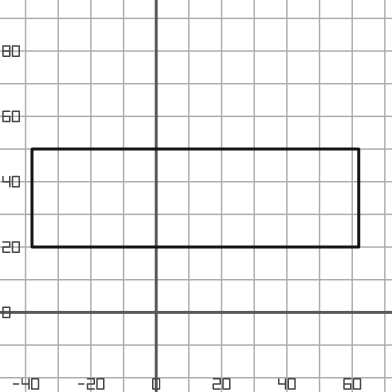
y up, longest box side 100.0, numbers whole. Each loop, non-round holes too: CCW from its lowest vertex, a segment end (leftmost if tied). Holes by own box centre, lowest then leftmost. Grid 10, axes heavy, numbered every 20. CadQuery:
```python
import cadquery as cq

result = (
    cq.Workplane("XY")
    .moveTo(-38.0, 20.0)
    .lineTo(62.0, 20.0)
    .lineTo(62.0, 50.0)
    .lineTo(-38.0, 50.0)
    .close()
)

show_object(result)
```